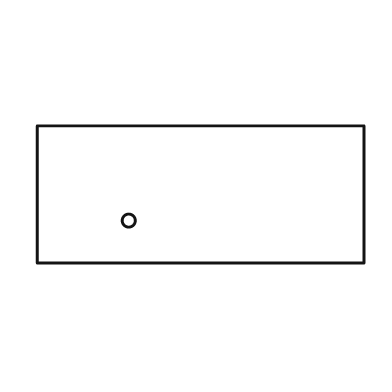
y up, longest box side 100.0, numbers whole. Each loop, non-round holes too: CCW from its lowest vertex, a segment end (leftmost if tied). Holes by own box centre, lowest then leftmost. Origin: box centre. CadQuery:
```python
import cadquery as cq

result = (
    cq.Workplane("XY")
    .moveTo(-50.0, -21.0)
    .lineTo(50.0, -21.0)
    .lineTo(50.0, 21.0)
    .lineTo(-50.0, 21.0)
    .close()
    .moveTo(-22.0, -8.0)
    .circle(2.0)
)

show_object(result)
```